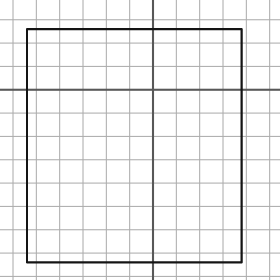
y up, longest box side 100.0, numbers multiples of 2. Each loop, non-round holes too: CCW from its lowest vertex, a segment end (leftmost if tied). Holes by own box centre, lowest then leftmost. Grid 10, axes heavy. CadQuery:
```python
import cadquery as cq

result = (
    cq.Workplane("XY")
    .moveTo(-54.0, -74.0)
    .lineTo(38.0, -74.0)
    .lineTo(38.0, 26.0)
    .lineTo(-54.0, 26.0)
    .close()
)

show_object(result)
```